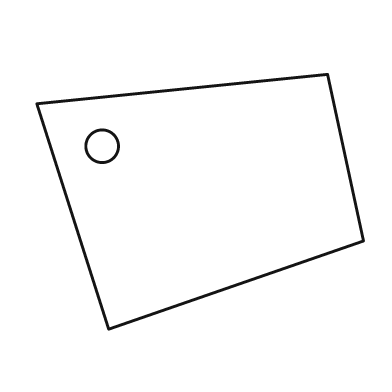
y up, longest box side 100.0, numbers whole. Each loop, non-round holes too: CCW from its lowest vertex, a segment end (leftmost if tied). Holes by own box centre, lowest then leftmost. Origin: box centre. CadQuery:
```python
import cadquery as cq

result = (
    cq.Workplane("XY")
    .moveTo(-28.0, -39.0)
    .lineTo(50.0, -12.0)
    .lineTo(39.0, 39.0)
    .lineTo(-50.0, 30.0)
    .close()
    .moveTo(-30.0, 17.0)
    .circle(5.0)
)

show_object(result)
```